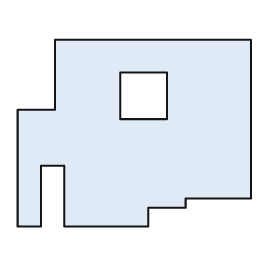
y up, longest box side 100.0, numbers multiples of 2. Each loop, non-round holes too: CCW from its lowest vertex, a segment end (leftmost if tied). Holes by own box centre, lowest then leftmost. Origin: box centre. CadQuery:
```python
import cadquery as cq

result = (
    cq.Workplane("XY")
    .moveTo(-50.0, -40.0)
    .lineTo(-40.0, -40.0)
    .lineTo(-40.0, -14.0)
    .lineTo(-30.0, -14.0)
    .lineTo(-30.0, -40.0)
    .lineTo(6.0, -40.0)
    .lineTo(6.0, -32.0)
    .lineTo(22.0, -32.0)
    .lineTo(22.0, -28.0)
    .lineTo(50.0, -28.0)
    .lineTo(50.0, 40.0)
    .lineTo(-34.0, 40.0)
    .lineTo(-34.0, 10.0)
    .lineTo(-50.0, 10.0)
    .close()
    .moveTo(-6.0, 6.0)
    .lineTo(14.0, 6.0)
    .lineTo(14.0, 26.0)
    .lineTo(-6.0, 26.0)
    .close()
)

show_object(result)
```